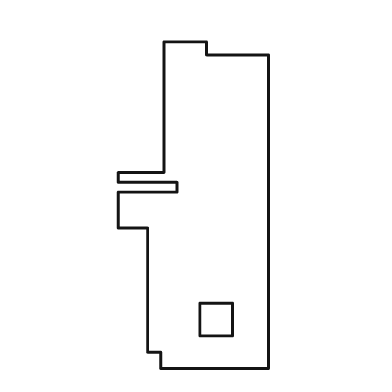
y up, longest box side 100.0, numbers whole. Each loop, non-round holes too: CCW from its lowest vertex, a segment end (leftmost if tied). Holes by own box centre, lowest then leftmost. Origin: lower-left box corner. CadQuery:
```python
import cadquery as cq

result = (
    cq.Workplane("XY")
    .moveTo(13.0, 0.0)
    .lineTo(46.0, 0.0)
    .lineTo(46.0, 96.0)
    .lineTo(27.0, 96.0)
    .lineTo(27.0, 100.0)
    .lineTo(14.0, 100.0)
    .lineTo(14.0, 60.0)
    .lineTo(0.0, 60.0)
    .lineTo(0.0, 57.0)
    .lineTo(18.0, 57.0)
    .lineTo(18.0, 54.0)
    .lineTo(0.0, 54.0)
    .lineTo(0.0, 43.0)
    .lineTo(9.0, 43.0)
    .lineTo(9.0, 5.0)
    .lineTo(13.0, 5.0)
    .close()
    .moveTo(25.0, 10.0)
    .lineTo(35.0, 10.0)
    .lineTo(35.0, 20.0)
    .lineTo(25.0, 20.0)
    .close()
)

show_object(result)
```